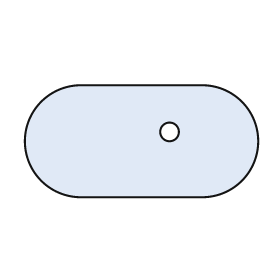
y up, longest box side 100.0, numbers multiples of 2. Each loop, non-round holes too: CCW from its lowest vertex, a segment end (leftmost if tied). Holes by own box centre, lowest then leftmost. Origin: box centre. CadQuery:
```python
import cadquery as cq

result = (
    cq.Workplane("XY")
    .moveTo(-26.0, -24.0)
    .lineTo(26.0, -24.0)
    .threePointArc((50.0, 0.0), (26.0, 24.0))
    .lineTo(-26.0, 24.0)
    .threePointArc((-50.0, 0.0), (-26.0, -24.0))
    .close()
    .moveTo(12.0, 4.0)
    .circle(4.0)
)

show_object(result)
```